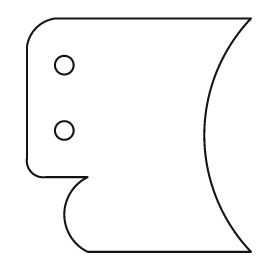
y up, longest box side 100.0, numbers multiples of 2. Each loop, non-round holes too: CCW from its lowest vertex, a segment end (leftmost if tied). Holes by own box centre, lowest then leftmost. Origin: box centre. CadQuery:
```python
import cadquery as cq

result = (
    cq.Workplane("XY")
    .moveTo(-22.0, -50.0)
    .lineTo(48.0, -50.0)
    .threePointArc((28.0, 0.0), (48.0, 50.0))
    .lineTo(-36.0, 50.0)
    .threePointArc((-44.0, 46.0), (-48.0, 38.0))
    .lineTo(-48.0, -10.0)
    .threePointArc((-46.0, -16.0), (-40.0, -18.0))
    .lineTo(-22.0, -18.0)
    .threePointArc((-32.0, -34.0), (-22.0, -50.0))
    .close()
    .moveTo(-32.0, 2.0)
    .circle(4.0)
    .moveTo(-32.0, 30.0)
    .circle(4.0)
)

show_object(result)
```